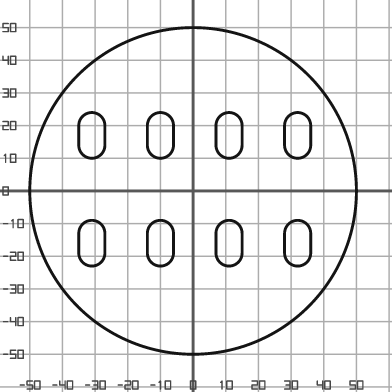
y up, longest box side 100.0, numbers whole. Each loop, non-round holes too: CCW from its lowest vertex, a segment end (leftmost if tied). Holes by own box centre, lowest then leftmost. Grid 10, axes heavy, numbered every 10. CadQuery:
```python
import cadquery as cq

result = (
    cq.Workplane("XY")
    .moveTo(0.0, 0.0)
    .circle(50.0)
    .moveTo(-35.0, -19.0)
    .threePointArc((-31.0, -23.0), (-27.0, -19.0))
    .lineTo(-27.0, -13.0)
    .threePointArc((-31.0, -9.0), (-35.0, -13.0))
    .close()
    .moveTo(-14.0, -19.0)
    .threePointArc((-10.0, -23.0), (-6.0, -19.0))
    .lineTo(-6.0, -13.0)
    .threePointArc((-10.0, -9.0), (-14.0, -13.0))
    .close()
    .moveTo(7.0, -19.0)
    .threePointArc((11.0, -23.0), (15.0, -19.0))
    .lineTo(15.0, -13.0)
    .threePointArc((11.0, -9.0), (7.0, -13.0))
    .close()
    .moveTo(28.0, -19.0)
    .threePointArc((32.0, -23.0), (36.0, -19.0))
    .lineTo(36.0, -13.0)
    .threePointArc((32.0, -9.0), (28.0, -13.0))
    .close()
    .moveTo(-35.0, 14.0)
    .threePointArc((-31.0, 10.0), (-27.0, 14.0))
    .lineTo(-27.0, 20.0)
    .threePointArc((-31.0, 24.0), (-35.0, 20.0))
    .close()
    .moveTo(-14.0, 14.0)
    .threePointArc((-10.0, 10.0), (-6.0, 14.0))
    .lineTo(-6.0, 20.0)
    .threePointArc((-10.0, 24.0), (-14.0, 20.0))
    .close()
    .moveTo(7.0, 14.0)
    .threePointArc((11.0, 10.0), (15.0, 14.0))
    .lineTo(15.0, 20.0)
    .threePointArc((11.0, 24.0), (7.0, 20.0))
    .close()
    .moveTo(28.0, 14.0)
    .threePointArc((32.0, 10.0), (36.0, 14.0))
    .lineTo(36.0, 20.0)
    .threePointArc((32.0, 24.0), (28.0, 20.0))
    .close()
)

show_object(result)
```